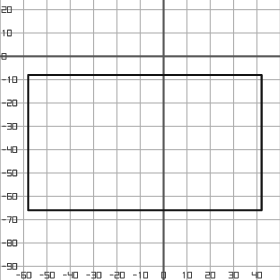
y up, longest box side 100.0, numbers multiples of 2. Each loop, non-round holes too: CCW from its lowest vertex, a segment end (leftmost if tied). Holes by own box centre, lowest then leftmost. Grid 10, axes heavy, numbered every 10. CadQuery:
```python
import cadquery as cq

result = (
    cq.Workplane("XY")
    .moveTo(-58.0, -66.0)
    .lineTo(42.0, -66.0)
    .lineTo(42.0, -8.0)
    .lineTo(-58.0, -8.0)
    .close()
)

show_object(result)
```